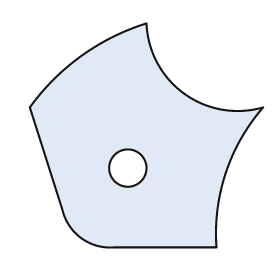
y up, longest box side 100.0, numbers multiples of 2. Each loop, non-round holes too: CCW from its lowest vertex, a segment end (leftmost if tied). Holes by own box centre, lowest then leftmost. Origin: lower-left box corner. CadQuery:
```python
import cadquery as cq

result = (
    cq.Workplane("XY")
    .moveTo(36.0, 0.0)
    .lineTo(80.0, 0.0)
    .threePointArc((84.0, 32.0), (100.0, 60.0))
    .threePointArc((66.0, 66.0), (50.0, 96.0))
    .threePointArc((22.0, 82.0), (0.0, 60.0))
    .lineTo(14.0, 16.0)
    .threePointArc((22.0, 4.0), (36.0, 0.0))
    .close()
    .moveTo(42.0, 34.0)
    .circle(8.0)
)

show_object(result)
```